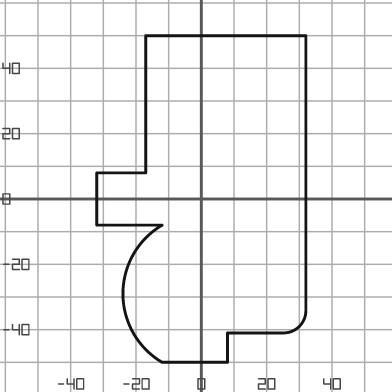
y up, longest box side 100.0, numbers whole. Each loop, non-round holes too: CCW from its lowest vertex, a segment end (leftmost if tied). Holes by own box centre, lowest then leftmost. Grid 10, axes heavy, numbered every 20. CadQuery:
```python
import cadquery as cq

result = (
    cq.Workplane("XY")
    .moveTo(-12.0, -50.0)
    .lineTo(8.0, -50.0)
    .lineTo(8.0, -41.0)
    .lineTo(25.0, -41.0)
    .threePointArc((30.0, -39.0), (32.0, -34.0))
    .lineTo(32.0, 50.0)
    .lineTo(-17.0, 50.0)
    .lineTo(-17.0, 8.0)
    .lineTo(-32.0, 8.0)
    .lineTo(-32.0, -8.0)
    .lineTo(-12.0, -8.0)
    .threePointArc((-24.0, -29.0), (-12.0, -50.0))
    .close()
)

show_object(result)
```